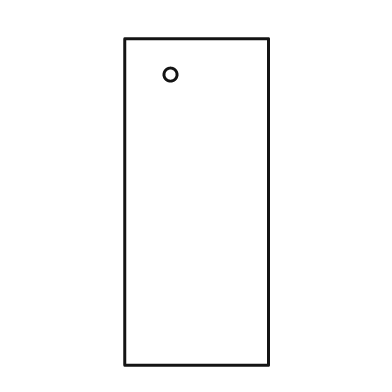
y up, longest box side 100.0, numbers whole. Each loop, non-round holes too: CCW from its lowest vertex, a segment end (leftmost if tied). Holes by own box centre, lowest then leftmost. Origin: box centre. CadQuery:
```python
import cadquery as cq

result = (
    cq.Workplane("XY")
    .moveTo(-22.0, -50.0)
    .lineTo(22.0, -50.0)
    .lineTo(22.0, 50.0)
    .lineTo(-22.0, 50.0)
    .close()
    .moveTo(-8.0, 39.0)
    .circle(2.0)
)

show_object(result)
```